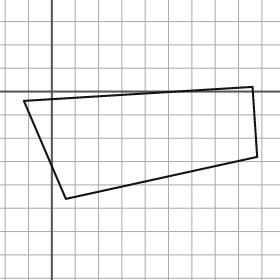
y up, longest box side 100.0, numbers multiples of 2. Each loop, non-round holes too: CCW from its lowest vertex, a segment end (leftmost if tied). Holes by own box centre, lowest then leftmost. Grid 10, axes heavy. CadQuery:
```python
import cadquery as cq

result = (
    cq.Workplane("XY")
    .moveTo(6.0, -46.0)
    .lineTo(88.0, -28.0)
    .lineTo(86.0, 2.0)
    .lineTo(-12.0, -4.0)
    .close()
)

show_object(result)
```